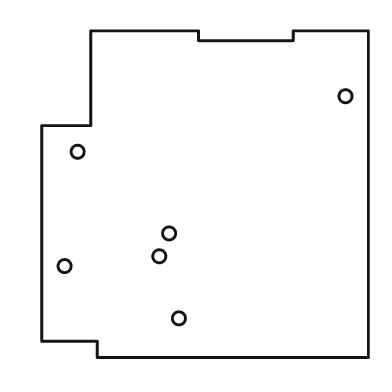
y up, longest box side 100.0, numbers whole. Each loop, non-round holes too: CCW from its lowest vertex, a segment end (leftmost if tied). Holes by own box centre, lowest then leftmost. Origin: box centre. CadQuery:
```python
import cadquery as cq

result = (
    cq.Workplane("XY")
    .moveTo(-33.0, -50.0)
    .lineTo(50.0, -50.0)
    .lineTo(50.0, 50.0)
    .lineTo(27.0, 50.0)
    .lineTo(27.0, 47.0)
    .lineTo(-2.0, 47.0)
    .lineTo(-2.0, 50.0)
    .lineTo(-35.0, 50.0)
    .lineTo(-35.0, 21.0)
    .lineTo(-50.0, 21.0)
    .lineTo(-50.0, -45.0)
    .lineTo(-33.0, -45.0)
    .close()
    .moveTo(-8.0, -38.0)
    .circle(2.0)
    .moveTo(-43.0, -22.0)
    .circle(2.0)
    .moveTo(-14.0, -19.0)
    .circle(2.0)
    .moveTo(-11.0, -12.0)
    .circle(2.0)
    .moveTo(-39.0, 13.0)
    .circle(2.0)
    .moveTo(43.0, 30.0)
    .circle(2.0)
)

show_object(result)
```